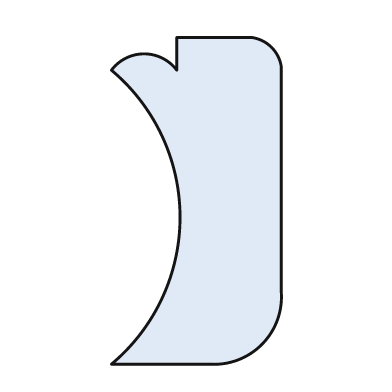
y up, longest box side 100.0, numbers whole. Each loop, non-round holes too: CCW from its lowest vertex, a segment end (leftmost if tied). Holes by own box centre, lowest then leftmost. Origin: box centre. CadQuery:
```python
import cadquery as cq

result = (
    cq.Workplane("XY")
    .moveTo(-26.0, -50.0)
    .lineTo(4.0, -50.0)
    .threePointArc((20.0, -44.0), (26.0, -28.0))
    .lineTo(26.0, 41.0)
    .threePointArc((23.0, 47.0), (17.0, 50.0))
    .lineTo(-6.0, 50.0)
    .lineTo(-6.0, 40.0)
    .threePointArc((-16.0, 45.0), (-26.0, 40.0))
    .threePointArc((-5.0, -5.0), (-26.0, -50.0))
    .close()
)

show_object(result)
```